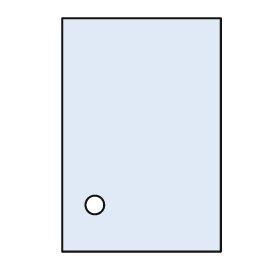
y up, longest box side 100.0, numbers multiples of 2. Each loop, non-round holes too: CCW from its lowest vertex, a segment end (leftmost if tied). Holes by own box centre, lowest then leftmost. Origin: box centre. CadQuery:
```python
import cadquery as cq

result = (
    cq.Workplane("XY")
    .moveTo(-34.0, -50.0)
    .lineTo(34.0, -50.0)
    .lineTo(34.0, 50.0)
    .lineTo(-34.0, 50.0)
    .close()
    .moveTo(-20.0, -30.0)
    .circle(4.0)
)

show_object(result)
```